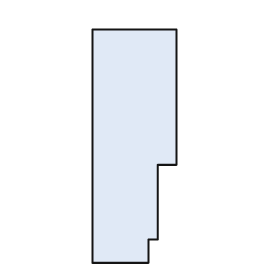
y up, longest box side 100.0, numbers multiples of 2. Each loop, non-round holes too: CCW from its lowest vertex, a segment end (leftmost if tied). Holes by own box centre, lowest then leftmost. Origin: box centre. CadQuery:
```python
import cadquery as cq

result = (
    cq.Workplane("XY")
    .moveTo(-18.0, -50.0)
    .lineTo(6.0, -50.0)
    .lineTo(6.0, -40.0)
    .lineTo(10.0, -40.0)
    .lineTo(10.0, -8.0)
    .lineTo(18.0, -8.0)
    .lineTo(18.0, 50.0)
    .lineTo(-18.0, 50.0)
    .close()
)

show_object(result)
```